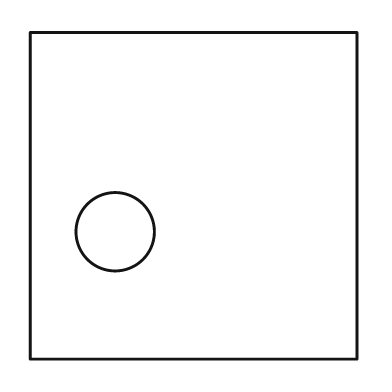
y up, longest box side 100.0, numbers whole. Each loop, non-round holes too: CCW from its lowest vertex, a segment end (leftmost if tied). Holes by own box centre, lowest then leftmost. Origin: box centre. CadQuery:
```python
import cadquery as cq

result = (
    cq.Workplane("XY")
    .moveTo(-50.0, -50.0)
    .lineTo(50.0, -50.0)
    .lineTo(50.0, 50.0)
    .lineTo(-50.0, 50.0)
    .close()
    .moveTo(-24.0, -11.0)
    .circle(12.0)
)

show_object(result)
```